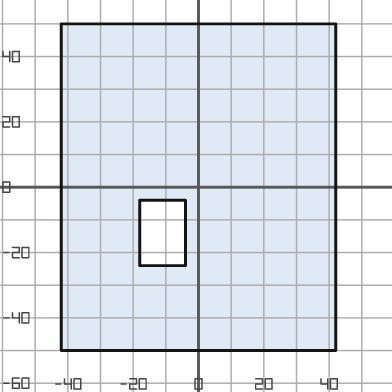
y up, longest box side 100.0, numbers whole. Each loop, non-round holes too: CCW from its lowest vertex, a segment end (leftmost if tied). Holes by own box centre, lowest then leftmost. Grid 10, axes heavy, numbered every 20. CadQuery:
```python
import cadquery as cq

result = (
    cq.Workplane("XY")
    .moveTo(-42.0, -50.0)
    .lineTo(42.0, -50.0)
    .lineTo(42.0, 50.0)
    .lineTo(-42.0, 50.0)
    .close()
    .moveTo(-18.0, -24.0)
    .lineTo(-4.0, -24.0)
    .lineTo(-4.0, -4.0)
    .lineTo(-18.0, -4.0)
    .close()
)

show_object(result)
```